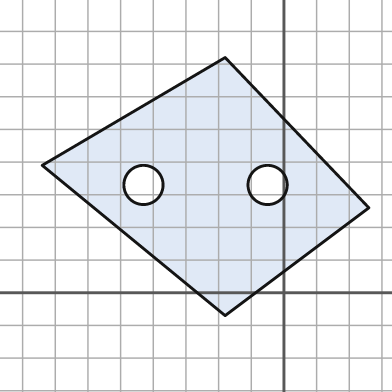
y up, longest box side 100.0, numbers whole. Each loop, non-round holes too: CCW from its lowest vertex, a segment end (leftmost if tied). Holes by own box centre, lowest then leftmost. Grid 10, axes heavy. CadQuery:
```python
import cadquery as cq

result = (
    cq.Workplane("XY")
    .moveTo(-18.0, -7.0)
    .lineTo(26.0, 26.0)
    .lineTo(-18.0, 72.0)
    .lineTo(-74.0, 39.0)
    .close()
    .moveTo(-43.0, 33.0)
    .circle(6.0)
    .moveTo(-5.0, 33.0)
    .circle(6.0)
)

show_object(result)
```